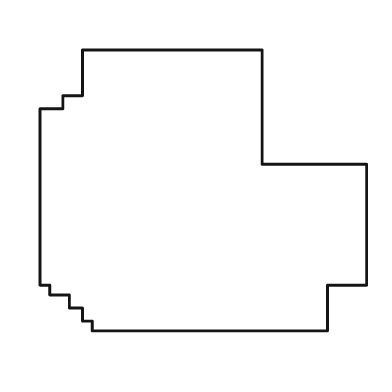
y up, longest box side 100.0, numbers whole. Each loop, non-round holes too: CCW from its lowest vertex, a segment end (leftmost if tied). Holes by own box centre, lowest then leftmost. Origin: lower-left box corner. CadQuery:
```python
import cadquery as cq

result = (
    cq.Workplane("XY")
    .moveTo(16.0, 0.0)
    .lineTo(88.0, 0.0)
    .lineTo(88.0, 14.0)
    .lineTo(100.0, 14.0)
    .lineTo(100.0, 51.0)
    .lineTo(68.0, 51.0)
    .lineTo(68.0, 86.0)
    .lineTo(13.0, 86.0)
    .lineTo(13.0, 72.0)
    .lineTo(7.0, 72.0)
    .lineTo(7.0, 68.0)
    .lineTo(0.0, 68.0)
    .lineTo(0.0, 14.0)
    .lineTo(3.0, 14.0)
    .lineTo(3.0, 11.0)
    .lineTo(9.0, 11.0)
    .lineTo(9.0, 7.0)
    .lineTo(13.0, 7.0)
    .lineTo(13.0, 3.0)
    .lineTo(16.0, 3.0)
    .close()
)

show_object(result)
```